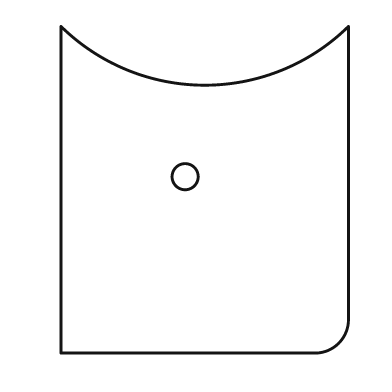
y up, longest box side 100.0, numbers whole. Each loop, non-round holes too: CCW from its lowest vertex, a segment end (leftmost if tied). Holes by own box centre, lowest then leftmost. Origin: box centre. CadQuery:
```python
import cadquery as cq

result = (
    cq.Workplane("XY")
    .moveTo(-44.0, -50.0)
    .lineTo(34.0, -50.0)
    .threePointArc((41.0, -47.0), (44.0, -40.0))
    .lineTo(44.0, 50.0)
    .threePointArc((0.0, 32.0), (-44.0, 50.0))
    .close()
    .moveTo(-6.0, 4.0)
    .circle(4.0)
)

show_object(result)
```